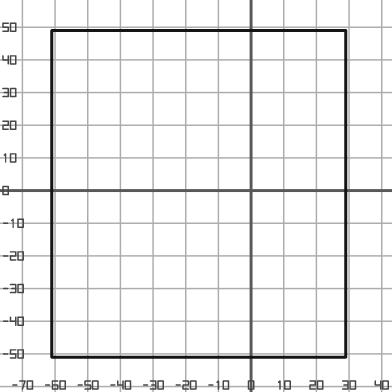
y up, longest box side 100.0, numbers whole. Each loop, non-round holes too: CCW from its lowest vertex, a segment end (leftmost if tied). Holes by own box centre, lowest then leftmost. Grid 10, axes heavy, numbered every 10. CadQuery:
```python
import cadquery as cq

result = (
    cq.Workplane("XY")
    .moveTo(-61.0, -51.0)
    .lineTo(29.0, -51.0)
    .lineTo(29.0, 49.0)
    .lineTo(-61.0, 49.0)
    .close()
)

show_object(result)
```